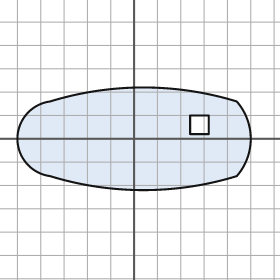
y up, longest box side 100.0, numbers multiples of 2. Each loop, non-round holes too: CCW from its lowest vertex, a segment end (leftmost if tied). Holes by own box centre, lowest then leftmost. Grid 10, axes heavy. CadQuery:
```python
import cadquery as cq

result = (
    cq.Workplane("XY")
    .moveTo(-36.0, -16.0)
    .threePointArc((4.0, -22.0), (44.0, -16.0))
    .threePointArc((50.0, 0.0), (44.0, 16.0))
    .threePointArc((4.0, 22.0), (-36.0, 16.0))
    .threePointArc((-50.0, 0.0), (-36.0, -16.0))
    .close()
    .moveTo(24.0, 2.0)
    .lineTo(32.0, 2.0)
    .lineTo(32.0, 10.0)
    .lineTo(24.0, 10.0)
    .close()
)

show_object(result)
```